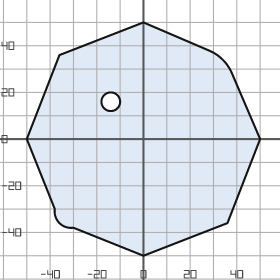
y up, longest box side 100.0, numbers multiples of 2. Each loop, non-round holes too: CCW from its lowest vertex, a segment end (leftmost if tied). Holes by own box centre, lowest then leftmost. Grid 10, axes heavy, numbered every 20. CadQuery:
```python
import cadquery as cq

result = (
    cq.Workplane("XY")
    .moveTo(0.0, -50.0)
    .lineTo(36.0, -36.0)
    .lineTo(50.0, 0.0)
    .lineTo(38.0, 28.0)
    .threePointArc((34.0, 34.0), (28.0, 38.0))
    .lineTo(0.0, 50.0)
    .lineTo(-36.0, 36.0)
    .lineTo(-50.0, 0.0)
    .lineTo(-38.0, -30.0)
    .threePointArc((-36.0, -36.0), (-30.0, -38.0))
    .close()
    .moveTo(-14.0, 16.0)
    .circle(4.0)
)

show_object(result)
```